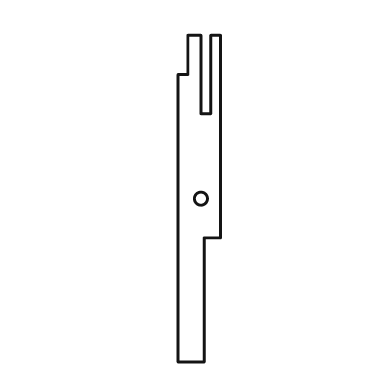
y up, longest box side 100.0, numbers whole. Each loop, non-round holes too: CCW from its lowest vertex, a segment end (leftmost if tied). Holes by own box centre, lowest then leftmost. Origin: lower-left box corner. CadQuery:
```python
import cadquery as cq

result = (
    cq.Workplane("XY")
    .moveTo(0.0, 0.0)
    .lineTo(8.0, 0.0)
    .lineTo(8.0, 38.0)
    .lineTo(13.0, 38.0)
    .lineTo(13.0, 100.0)
    .lineTo(10.0, 100.0)
    .lineTo(10.0, 76.0)
    .lineTo(7.0, 76.0)
    .lineTo(7.0, 100.0)
    .lineTo(3.0, 100.0)
    .lineTo(3.0, 88.0)
    .lineTo(0.0, 88.0)
    .close()
    .moveTo(7.0, 50.0)
    .circle(2.0)
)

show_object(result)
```